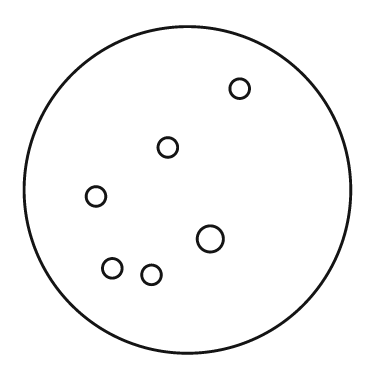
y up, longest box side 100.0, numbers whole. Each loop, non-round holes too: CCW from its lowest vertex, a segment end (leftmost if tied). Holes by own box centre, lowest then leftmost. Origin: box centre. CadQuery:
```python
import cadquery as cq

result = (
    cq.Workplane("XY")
    .moveTo(0.0, 0.0)
    .circle(50.0)
    .moveTo(-11.0, -26.0)
    .circle(3.0)
    .moveTo(-23.0, -24.0)
    .circle(3.0)
    .moveTo(7.0, -15.0)
    .circle(4.0)
    .moveTo(-28.0, -2.0)
    .circle(3.0)
    .moveTo(-6.0, 13.0)
    .circle(3.0)
    .moveTo(16.0, 31.0)
    .circle(3.0)
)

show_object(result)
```